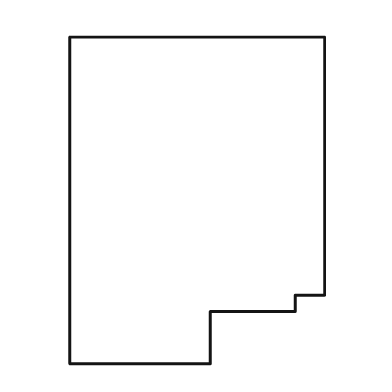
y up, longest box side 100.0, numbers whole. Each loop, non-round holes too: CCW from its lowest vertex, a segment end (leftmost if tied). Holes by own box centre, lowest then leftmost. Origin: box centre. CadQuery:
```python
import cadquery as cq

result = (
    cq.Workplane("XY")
    .moveTo(-39.0, -50.0)
    .lineTo(4.0, -50.0)
    .lineTo(4.0, -34.0)
    .lineTo(30.0, -34.0)
    .lineTo(30.0, -29.0)
    .lineTo(39.0, -29.0)
    .lineTo(39.0, 50.0)
    .lineTo(-39.0, 50.0)
    .close()
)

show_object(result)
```